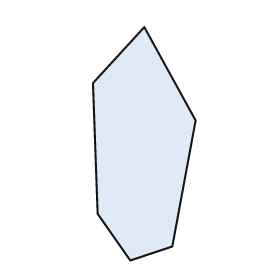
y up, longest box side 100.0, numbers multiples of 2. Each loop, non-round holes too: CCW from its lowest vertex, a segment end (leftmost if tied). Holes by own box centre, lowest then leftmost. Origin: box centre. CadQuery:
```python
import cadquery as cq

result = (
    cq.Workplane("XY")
    .moveTo(-6.0, -50.0)
    .lineTo(12.0, -44.0)
    .lineTo(22.0, 10.0)
    .lineTo(0.0, 50.0)
    .lineTo(-22.0, 26.0)
    .lineTo(-20.0, -30.0)
    .close()
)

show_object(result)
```